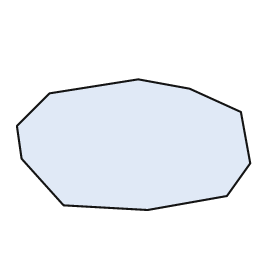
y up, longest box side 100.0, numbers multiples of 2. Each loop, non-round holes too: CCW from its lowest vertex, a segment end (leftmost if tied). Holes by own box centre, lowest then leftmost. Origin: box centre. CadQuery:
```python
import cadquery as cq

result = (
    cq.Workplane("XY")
    .moveTo(6.0, -28.0)
    .lineTo(40.0, -22.0)
    .lineTo(50.0, -8.0)
    .lineTo(46.0, 14.0)
    .lineTo(24.0, 24.0)
    .lineTo(2.0, 28.0)
    .lineTo(-36.0, 22.0)
    .lineTo(-50.0, 8.0)
    .lineTo(-48.0, -6.0)
    .lineTo(-30.0, -26.0)
    .close()
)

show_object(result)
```